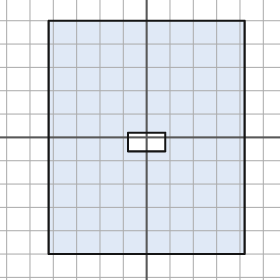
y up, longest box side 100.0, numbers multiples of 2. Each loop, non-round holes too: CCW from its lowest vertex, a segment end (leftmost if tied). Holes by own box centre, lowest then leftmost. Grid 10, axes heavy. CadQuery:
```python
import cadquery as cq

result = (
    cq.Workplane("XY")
    .moveTo(-42.0, -50.0)
    .lineTo(42.0, -50.0)
    .lineTo(42.0, 50.0)
    .lineTo(-42.0, 50.0)
    .close()
    .moveTo(-8.0, -6.0)
    .lineTo(8.0, -6.0)
    .lineTo(8.0, 2.0)
    .lineTo(-8.0, 2.0)
    .close()
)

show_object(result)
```